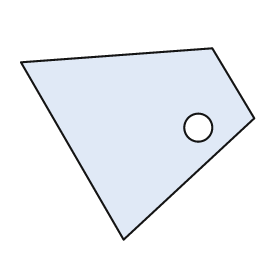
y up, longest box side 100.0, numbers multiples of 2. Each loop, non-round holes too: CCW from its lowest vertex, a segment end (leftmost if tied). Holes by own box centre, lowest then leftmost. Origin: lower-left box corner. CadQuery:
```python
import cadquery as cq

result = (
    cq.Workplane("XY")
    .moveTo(44.0, 0.0)
    .lineTo(100.0, 52.0)
    .lineTo(82.0, 82.0)
    .lineTo(0.0, 76.0)
    .close()
    .moveTo(76.0, 48.0)
    .circle(6.0)
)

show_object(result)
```